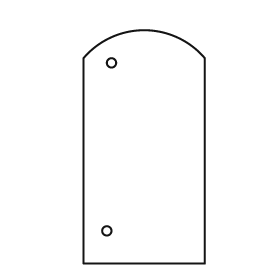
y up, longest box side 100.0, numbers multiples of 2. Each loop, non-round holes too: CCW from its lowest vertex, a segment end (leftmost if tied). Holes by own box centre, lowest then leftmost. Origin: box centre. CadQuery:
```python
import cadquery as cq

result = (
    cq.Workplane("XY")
    .moveTo(-26.0, -50.0)
    .lineTo(26.0, -50.0)
    .lineTo(26.0, 38.0)
    .threePointArc((0.0, 50.0), (-26.0, 38.0))
    .close()
    .moveTo(-16.0, -36.0)
    .circle(2.0)
    .moveTo(-14.0, 36.0)
    .circle(2.0)
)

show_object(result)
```